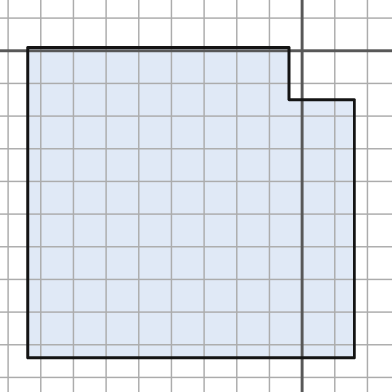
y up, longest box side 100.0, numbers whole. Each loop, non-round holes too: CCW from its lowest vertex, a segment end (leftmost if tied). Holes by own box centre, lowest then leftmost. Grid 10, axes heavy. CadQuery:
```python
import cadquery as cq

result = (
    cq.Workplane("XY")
    .moveTo(-84.0, -94.0)
    .lineTo(16.0, -94.0)
    .lineTo(16.0, -15.0)
    .lineTo(-4.0, -15.0)
    .lineTo(-4.0, 1.0)
    .lineTo(-84.0, 1.0)
    .close()
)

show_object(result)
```